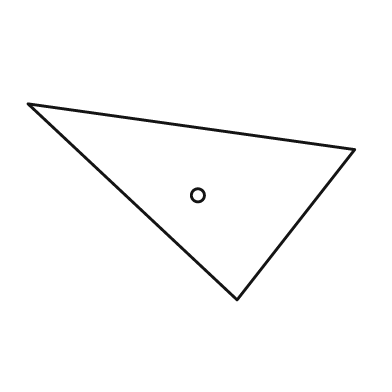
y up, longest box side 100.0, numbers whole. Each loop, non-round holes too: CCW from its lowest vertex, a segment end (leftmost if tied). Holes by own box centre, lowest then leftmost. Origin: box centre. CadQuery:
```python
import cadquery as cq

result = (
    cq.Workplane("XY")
    .moveTo(14.0, -30.0)
    .lineTo(50.0, 16.0)
    .lineTo(-50.0, 30.0)
    .close()
    .moveTo(2.0, 2.0)
    .circle(2.0)
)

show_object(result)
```